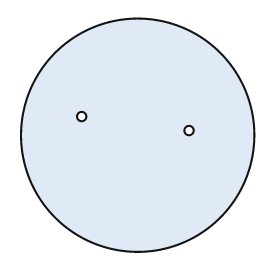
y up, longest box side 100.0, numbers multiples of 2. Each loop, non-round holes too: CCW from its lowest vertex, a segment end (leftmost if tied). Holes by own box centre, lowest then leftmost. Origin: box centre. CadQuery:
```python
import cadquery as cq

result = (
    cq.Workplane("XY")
    .moveTo(0.0, 0.0)
    .circle(50.0)
    .moveTo(22.0, 2.0)
    .circle(2.0)
    .moveTo(-24.0, 8.0)
    .circle(2.0)
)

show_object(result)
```